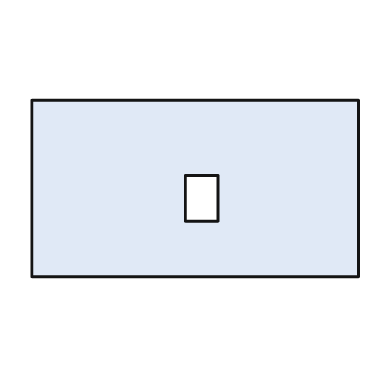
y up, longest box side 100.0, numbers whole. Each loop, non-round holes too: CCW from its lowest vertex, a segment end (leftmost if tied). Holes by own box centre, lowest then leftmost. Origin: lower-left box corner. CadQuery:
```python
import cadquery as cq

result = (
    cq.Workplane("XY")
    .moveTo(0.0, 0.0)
    .lineTo(100.0, 0.0)
    .lineTo(100.0, 54.0)
    .lineTo(0.0, 54.0)
    .close()
    .moveTo(47.0, 17.0)
    .lineTo(57.0, 17.0)
    .lineTo(57.0, 31.0)
    .lineTo(47.0, 31.0)
    .close()
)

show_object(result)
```